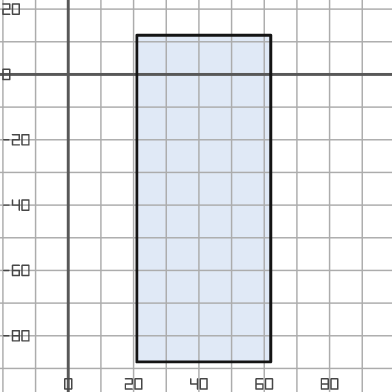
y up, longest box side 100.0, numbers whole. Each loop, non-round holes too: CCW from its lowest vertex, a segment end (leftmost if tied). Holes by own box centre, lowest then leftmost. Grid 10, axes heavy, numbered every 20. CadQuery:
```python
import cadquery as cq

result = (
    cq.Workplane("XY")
    .moveTo(21.0, -88.0)
    .lineTo(62.0, -88.0)
    .lineTo(62.0, 12.0)
    .lineTo(21.0, 12.0)
    .close()
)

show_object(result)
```